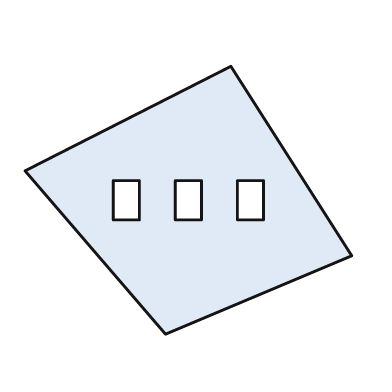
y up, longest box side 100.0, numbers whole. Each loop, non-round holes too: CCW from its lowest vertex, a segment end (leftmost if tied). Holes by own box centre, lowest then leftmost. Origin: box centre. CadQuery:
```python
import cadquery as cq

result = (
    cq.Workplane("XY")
    .moveTo(-7.0, -41.0)
    .lineTo(50.0, -17.0)
    .lineTo(13.0, 41.0)
    .lineTo(-50.0, 9.0)
    .close()
    .moveTo(-23.0, -6.0)
    .lineTo(-15.0, -6.0)
    .lineTo(-15.0, 6.0)
    .lineTo(-23.0, 6.0)
    .close()
    .moveTo(-4.0, -6.0)
    .lineTo(4.0, -6.0)
    .lineTo(4.0, 6.0)
    .lineTo(-4.0, 6.0)
    .close()
    .moveTo(15.0, -6.0)
    .lineTo(23.0, -6.0)
    .lineTo(23.0, 6.0)
    .lineTo(15.0, 6.0)
    .close()
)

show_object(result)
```